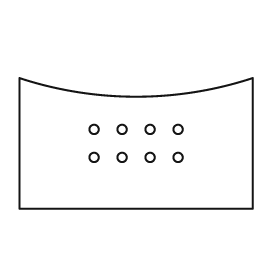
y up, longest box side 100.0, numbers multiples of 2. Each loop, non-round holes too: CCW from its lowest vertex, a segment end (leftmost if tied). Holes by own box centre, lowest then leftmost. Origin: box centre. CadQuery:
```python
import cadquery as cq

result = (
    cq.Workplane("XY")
    .moveTo(-50.0, -28.0)
    .lineTo(50.0, -28.0)
    .lineTo(50.0, 28.0)
    .threePointArc((0.0, 20.0), (-50.0, 28.0))
    .close()
    .moveTo(-18.0, -6.0)
    .circle(2.0)
    .moveTo(-6.0, -6.0)
    .circle(2.0)
    .moveTo(6.0, -6.0)
    .circle(2.0)
    .moveTo(18.0, -6.0)
    .circle(2.0)
    .moveTo(-18.0, 6.0)
    .circle(2.0)
    .moveTo(-6.0, 6.0)
    .circle(2.0)
    .moveTo(6.0, 6.0)
    .circle(2.0)
    .moveTo(18.0, 6.0)
    .circle(2.0)
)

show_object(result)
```